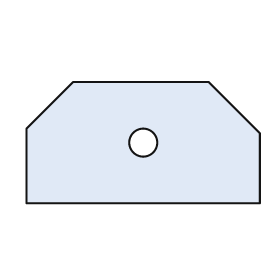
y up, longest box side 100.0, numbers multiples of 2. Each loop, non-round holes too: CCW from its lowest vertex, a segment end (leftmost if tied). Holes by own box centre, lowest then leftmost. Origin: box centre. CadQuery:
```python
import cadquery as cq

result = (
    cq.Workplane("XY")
    .moveTo(-50.0, -26.0)
    .lineTo(50.0, -26.0)
    .lineTo(50.0, 4.0)
    .lineTo(28.0, 26.0)
    .lineTo(-30.0, 26.0)
    .lineTo(-50.0, 6.0)
    .close()
    .moveTo(0.0, 0.0)
    .circle(6.0)
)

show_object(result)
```